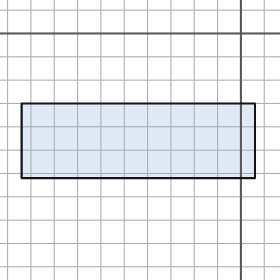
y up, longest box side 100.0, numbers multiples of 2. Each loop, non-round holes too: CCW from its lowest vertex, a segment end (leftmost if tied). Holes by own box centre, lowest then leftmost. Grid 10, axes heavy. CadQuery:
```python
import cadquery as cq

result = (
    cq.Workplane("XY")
    .moveTo(-94.0, -62.0)
    .lineTo(6.0, -62.0)
    .lineTo(6.0, -30.0)
    .lineTo(-94.0, -30.0)
    .close()
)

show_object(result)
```